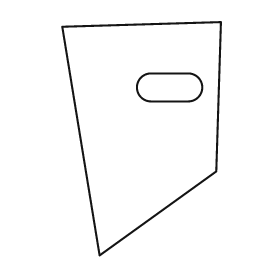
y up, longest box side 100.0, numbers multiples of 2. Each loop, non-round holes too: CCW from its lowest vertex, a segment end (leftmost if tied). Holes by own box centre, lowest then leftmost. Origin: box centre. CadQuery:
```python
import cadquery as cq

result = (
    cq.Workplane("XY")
    .moveTo(-18.0, -50.0)
    .lineTo(32.0, -14.0)
    .lineTo(34.0, 50.0)
    .lineTo(-34.0, 48.0)
    .close()
    .moveTo(4.0, 16.0)
    .lineTo(20.0, 16.0)
    .threePointArc((26.0, 22.0), (20.0, 28.0))
    .lineTo(4.0, 28.0)
    .threePointArc((-2.0, 22.0), (4.0, 16.0))
    .close()
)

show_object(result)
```